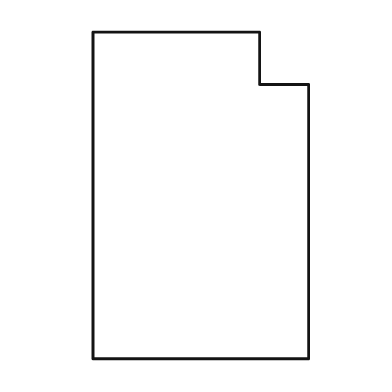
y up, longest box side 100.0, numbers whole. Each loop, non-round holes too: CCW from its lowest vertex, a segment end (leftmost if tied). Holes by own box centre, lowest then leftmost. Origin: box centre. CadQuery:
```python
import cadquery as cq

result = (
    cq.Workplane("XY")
    .moveTo(-33.0, -50.0)
    .lineTo(33.0, -50.0)
    .lineTo(33.0, 34.0)
    .lineTo(18.0, 34.0)
    .lineTo(18.0, 50.0)
    .lineTo(-33.0, 50.0)
    .close()
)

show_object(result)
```